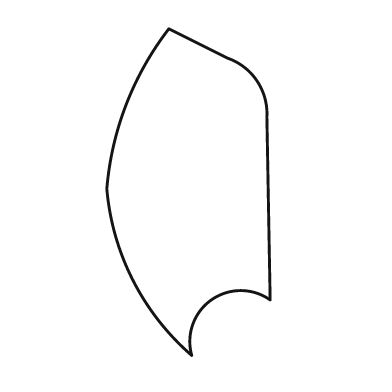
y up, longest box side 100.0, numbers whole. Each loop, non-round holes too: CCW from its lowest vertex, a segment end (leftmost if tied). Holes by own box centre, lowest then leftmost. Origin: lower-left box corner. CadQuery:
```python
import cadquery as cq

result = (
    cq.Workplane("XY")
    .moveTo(26.0, 0.0)
    .threePointArc((32.0, 17.0), (50.0, 17.0))
    .lineTo(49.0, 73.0)
    .threePointArc((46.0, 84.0), (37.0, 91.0))
    .lineTo(19.0, 100.0)
    .threePointArc((6.0, 77.0), (0.0, 51.0))
    .threePointArc((8.0, 23.0), (26.0, 0.0))
    .close()
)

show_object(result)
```